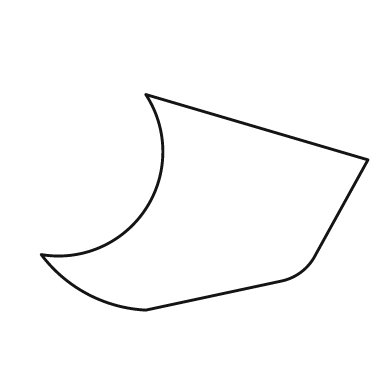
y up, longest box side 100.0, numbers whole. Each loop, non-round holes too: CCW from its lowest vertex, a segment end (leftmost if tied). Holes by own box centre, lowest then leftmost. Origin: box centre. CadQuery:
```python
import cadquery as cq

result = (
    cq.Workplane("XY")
    .moveTo(-18.0, -33.0)
    .lineTo(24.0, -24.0)
    .threePointArc((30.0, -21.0), (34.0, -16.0))
    .lineTo(50.0, 13.0)
    .lineTo(-18.0, 33.0)
    .threePointArc((-18.0, -2.0), (-50.0, -16.0))
    .threePointArc((-36.0, -28.0), (-18.0, -33.0))
    .close()
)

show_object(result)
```